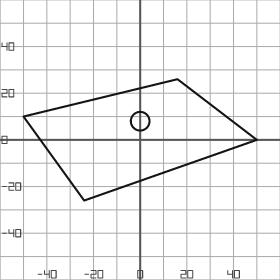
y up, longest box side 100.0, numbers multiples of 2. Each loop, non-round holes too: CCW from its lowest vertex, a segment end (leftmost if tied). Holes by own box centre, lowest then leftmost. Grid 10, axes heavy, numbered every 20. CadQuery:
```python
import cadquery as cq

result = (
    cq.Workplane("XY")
    .moveTo(-24.0, -26.0)
    .lineTo(50.0, 0.0)
    .lineTo(16.0, 26.0)
    .lineTo(-50.0, 10.0)
    .close()
    .moveTo(0.0, 8.0)
    .circle(4.0)
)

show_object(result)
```